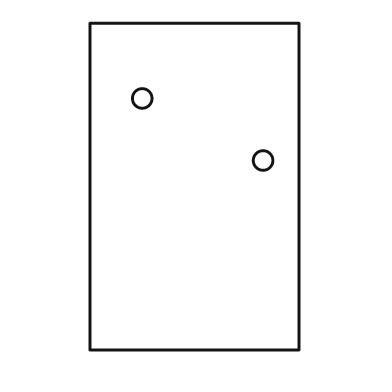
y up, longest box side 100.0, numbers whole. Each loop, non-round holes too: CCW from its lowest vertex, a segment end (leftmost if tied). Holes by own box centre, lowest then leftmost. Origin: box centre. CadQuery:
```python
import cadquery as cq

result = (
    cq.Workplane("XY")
    .moveTo(-32.0, -50.0)
    .lineTo(32.0, -50.0)
    .lineTo(32.0, 50.0)
    .lineTo(-32.0, 50.0)
    .close()
    .moveTo(21.0, 8.0)
    .circle(3.0)
    .moveTo(-16.0, 27.0)
    .circle(3.0)
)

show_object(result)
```